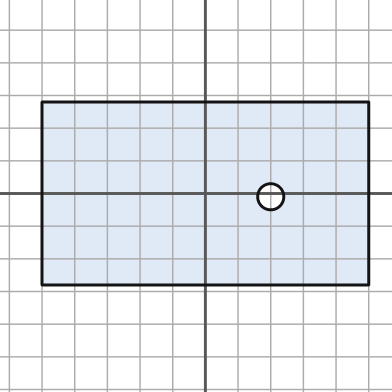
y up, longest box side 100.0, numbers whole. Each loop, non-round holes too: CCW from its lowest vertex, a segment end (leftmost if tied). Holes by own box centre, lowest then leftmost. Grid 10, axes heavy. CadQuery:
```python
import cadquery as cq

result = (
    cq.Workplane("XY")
    .moveTo(-50.0, -28.0)
    .lineTo(50.0, -28.0)
    .lineTo(50.0, 28.0)
    .lineTo(-50.0, 28.0)
    .close()
    .moveTo(20.0, -1.0)
    .circle(4.0)
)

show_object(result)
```